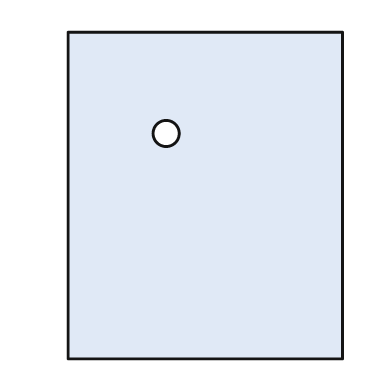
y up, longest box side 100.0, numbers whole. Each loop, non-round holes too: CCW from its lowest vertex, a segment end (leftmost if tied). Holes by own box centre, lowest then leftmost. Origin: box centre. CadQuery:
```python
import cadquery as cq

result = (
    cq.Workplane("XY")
    .moveTo(-42.0, -50.0)
    .lineTo(42.0, -50.0)
    .lineTo(42.0, 50.0)
    .lineTo(-42.0, 50.0)
    .close()
    .moveTo(-12.0, 19.0)
    .circle(4.0)
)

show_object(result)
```